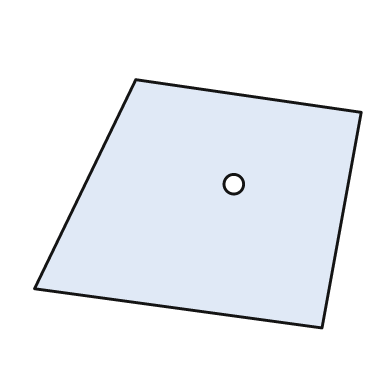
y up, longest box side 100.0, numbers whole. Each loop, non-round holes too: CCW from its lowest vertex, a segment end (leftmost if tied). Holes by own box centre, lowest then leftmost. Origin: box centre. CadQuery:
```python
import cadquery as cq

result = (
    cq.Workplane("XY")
    .moveTo(38.0, -38.0)
    .lineTo(50.0, 28.0)
    .lineTo(-19.0, 38.0)
    .lineTo(-50.0, -26.0)
    .close()
    .moveTo(11.0, 6.0)
    .circle(3.0)
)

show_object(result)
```